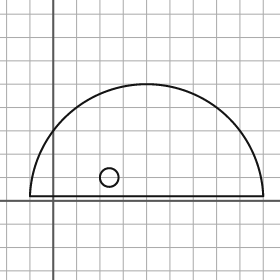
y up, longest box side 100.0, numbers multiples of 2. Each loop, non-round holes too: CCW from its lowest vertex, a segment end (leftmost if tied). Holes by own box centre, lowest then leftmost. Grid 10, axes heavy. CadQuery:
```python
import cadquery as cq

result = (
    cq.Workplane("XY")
    .moveTo(-10.0, 2.0)
    .lineTo(90.0, 2.0)
    .threePointArc((40.0, 50.0), (-10.0, 2.0))
    .close()
    .moveTo(24.0, 10.0)
    .circle(4.0)
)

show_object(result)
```